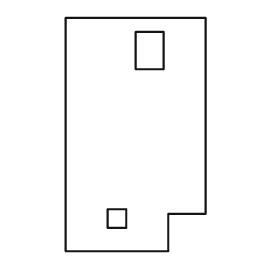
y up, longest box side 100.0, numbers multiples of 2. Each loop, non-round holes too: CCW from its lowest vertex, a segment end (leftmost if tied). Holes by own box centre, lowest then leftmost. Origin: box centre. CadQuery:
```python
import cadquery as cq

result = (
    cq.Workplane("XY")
    .moveTo(-30.0, -50.0)
    .lineTo(14.0, -50.0)
    .lineTo(14.0, -34.0)
    .lineTo(30.0, -34.0)
    .lineTo(30.0, 50.0)
    .lineTo(-30.0, 50.0)
    .close()
    .moveTo(-12.0, -40.0)
    .lineTo(-4.0, -40.0)
    .lineTo(-4.0, -32.0)
    .lineTo(-12.0, -32.0)
    .close()
    .moveTo(0.0, 28.0)
    .lineTo(12.0, 28.0)
    .lineTo(12.0, 44.0)
    .lineTo(0.0, 44.0)
    .close()
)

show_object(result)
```